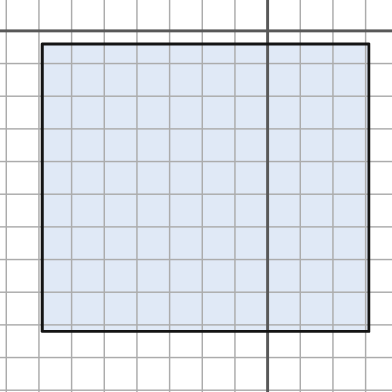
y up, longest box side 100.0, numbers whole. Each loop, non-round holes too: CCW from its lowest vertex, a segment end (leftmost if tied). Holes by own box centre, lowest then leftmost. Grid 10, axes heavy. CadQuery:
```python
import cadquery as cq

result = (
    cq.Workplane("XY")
    .moveTo(-69.0, -92.0)
    .lineTo(31.0, -92.0)
    .lineTo(31.0, -4.0)
    .lineTo(-69.0, -4.0)
    .close()
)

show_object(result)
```